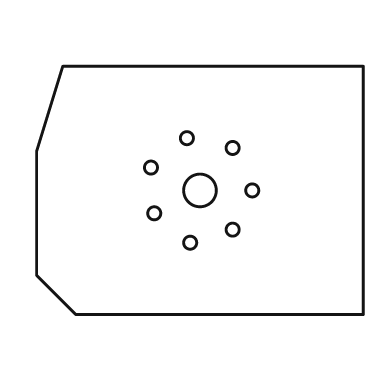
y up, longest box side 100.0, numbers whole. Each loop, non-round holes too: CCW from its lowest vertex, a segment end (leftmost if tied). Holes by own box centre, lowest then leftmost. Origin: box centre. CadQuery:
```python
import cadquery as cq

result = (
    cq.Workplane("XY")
    .moveTo(-38.0, -38.0)
    .lineTo(50.0, -38.0)
    .lineTo(50.0, 38.0)
    .lineTo(-42.0, 38.0)
    .lineTo(-50.0, 12.0)
    .lineTo(-50.0, -26.0)
    .close()
    .moveTo(-3.0, -16.0)
    .circle(2.0)
    .moveTo(10.0, -12.0)
    .circle(2.0)
    .moveTo(-14.0, -7.0)
    .circle(2.0)
    .moveTo(0.0, 0.0)
    .circle(5.0)
    .moveTo(16.0, 0.0)
    .circle(2.0)
    .moveTo(-15.0, 7.0)
    .circle(2.0)
    .moveTo(10.0, 13.0)
    .circle(2.0)
    .moveTo(-4.0, 16.0)
    .circle(2.0)
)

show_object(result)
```